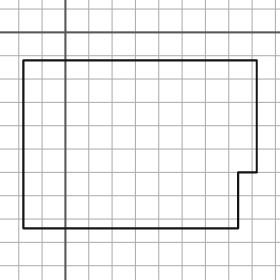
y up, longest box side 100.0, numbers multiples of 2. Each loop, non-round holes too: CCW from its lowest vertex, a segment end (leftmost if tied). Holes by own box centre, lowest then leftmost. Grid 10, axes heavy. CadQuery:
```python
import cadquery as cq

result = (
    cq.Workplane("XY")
    .moveTo(-18.0, -84.0)
    .lineTo(74.0, -84.0)
    .lineTo(74.0, -60.0)
    .lineTo(82.0, -60.0)
    .lineTo(82.0, -12.0)
    .lineTo(-18.0, -12.0)
    .close()
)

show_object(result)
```